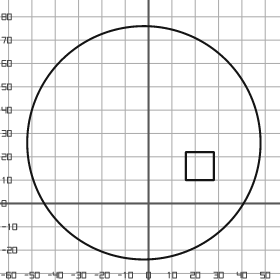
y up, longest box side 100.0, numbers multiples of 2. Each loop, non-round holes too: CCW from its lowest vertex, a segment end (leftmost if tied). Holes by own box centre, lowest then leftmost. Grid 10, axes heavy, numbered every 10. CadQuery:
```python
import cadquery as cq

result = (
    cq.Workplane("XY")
    .moveTo(-2.0, 26.0)
    .circle(50.0)
    .moveTo(16.0, 10.0)
    .lineTo(28.0, 10.0)
    .lineTo(28.0, 22.0)
    .lineTo(16.0, 22.0)
    .close()
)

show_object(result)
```